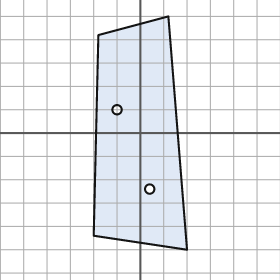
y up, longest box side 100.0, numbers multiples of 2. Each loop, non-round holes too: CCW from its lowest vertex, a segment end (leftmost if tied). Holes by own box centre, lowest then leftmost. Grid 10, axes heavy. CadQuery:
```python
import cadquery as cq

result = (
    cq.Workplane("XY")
    .moveTo(20.0, -50.0)
    .lineTo(12.0, 50.0)
    .lineTo(-18.0, 42.0)
    .lineTo(-20.0, -44.0)
    .close()
    .moveTo(4.0, -24.0)
    .circle(2.0)
    .moveTo(-10.0, 10.0)
    .circle(2.0)
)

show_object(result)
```